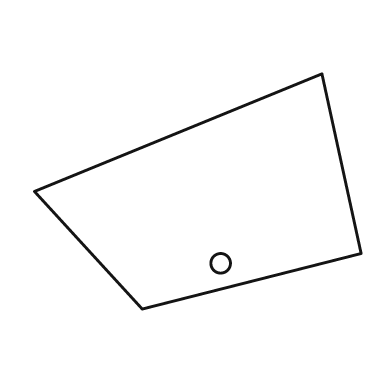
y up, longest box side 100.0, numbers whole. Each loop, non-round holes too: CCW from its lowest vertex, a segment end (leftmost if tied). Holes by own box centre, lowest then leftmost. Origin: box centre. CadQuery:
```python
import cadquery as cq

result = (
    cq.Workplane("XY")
    .moveTo(-17.0, -36.0)
    .lineTo(50.0, -19.0)
    .lineTo(38.0, 36.0)
    .lineTo(-50.0, 0.0)
    .close()
    .moveTo(7.0, -22.0)
    .circle(3.0)
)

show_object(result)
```